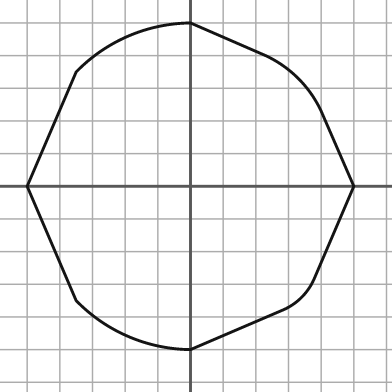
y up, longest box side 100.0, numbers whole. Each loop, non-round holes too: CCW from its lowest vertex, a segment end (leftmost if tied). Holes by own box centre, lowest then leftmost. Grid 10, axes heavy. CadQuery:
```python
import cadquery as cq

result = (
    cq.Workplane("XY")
    .moveTo(0.0, -50.0)
    .lineTo(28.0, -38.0)
    .threePointArc((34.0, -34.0), (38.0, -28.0))
    .lineTo(50.0, 0.0)
    .lineTo(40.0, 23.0)
    .threePointArc((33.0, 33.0), (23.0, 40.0))
    .lineTo(0.0, 50.0)
    .threePointArc((-19.0, 46.0), (-35.0, 35.0))
    .lineTo(-50.0, 0.0)
    .lineTo(-35.0, -35.0)
    .threePointArc((-19.0, -46.0), (0.0, -50.0))
    .close()
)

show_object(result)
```